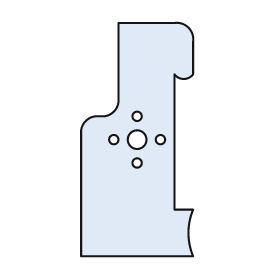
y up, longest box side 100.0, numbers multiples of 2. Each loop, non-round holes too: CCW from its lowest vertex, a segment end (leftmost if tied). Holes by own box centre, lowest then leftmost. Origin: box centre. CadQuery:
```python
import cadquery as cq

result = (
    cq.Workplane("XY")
    .moveTo(-24.0, -50.0)
    .lineTo(24.0, -50.0)
    .threePointArc((22.0, -40.0), (24.0, -30.0))
    .lineTo(16.0, -30.0)
    .lineTo(16.0, 28.0)
    .threePointArc((20.0, 26.0), (24.0, 28.0))
    .lineTo(24.0, 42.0)
    .threePointArc((22.0, 48.0), (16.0, 50.0))
    .lineTo(-8.0, 50.0)
    .lineTo(-8.0, 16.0)
    .threePointArc((-10.0, 12.0), (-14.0, 10.0))
    .lineTo(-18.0, 10.0)
    .threePointArc((-22.0, 8.0), (-24.0, 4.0))
    .close()
    .moveTo(0.0, -10.0)
    .circle(2.0)
    .moveTo(-10.0, 0.0)
    .circle(2.0)
    .moveTo(0.0, 0.0)
    .circle(4.0)
    .moveTo(10.0, 0.0)
    .circle(2.0)
    .moveTo(0.0, 10.0)
    .circle(2.0)
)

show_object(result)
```